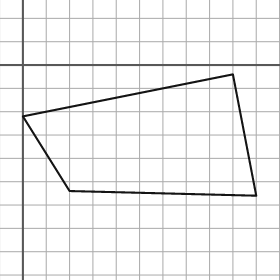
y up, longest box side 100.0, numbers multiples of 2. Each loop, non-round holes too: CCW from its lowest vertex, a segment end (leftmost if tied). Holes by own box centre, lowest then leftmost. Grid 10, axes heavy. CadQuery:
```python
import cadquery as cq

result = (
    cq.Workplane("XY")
    .moveTo(100.0, -56.0)
    .lineTo(90.0, -4.0)
    .lineTo(0.0, -22.0)
    .lineTo(20.0, -54.0)
    .close()
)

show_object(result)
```